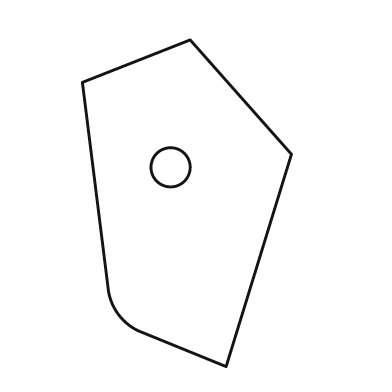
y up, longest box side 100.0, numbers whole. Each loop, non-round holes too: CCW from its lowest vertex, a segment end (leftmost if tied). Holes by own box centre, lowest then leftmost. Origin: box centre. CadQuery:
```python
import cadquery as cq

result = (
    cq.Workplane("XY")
    .moveTo(12.0, -50.0)
    .lineTo(32.0, 15.0)
    .lineTo(1.0, 50.0)
    .lineTo(-32.0, 37.0)
    .lineTo(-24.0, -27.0)
    .threePointArc((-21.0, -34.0), (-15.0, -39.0))
    .close()
    .moveTo(-5.0, 11.0)
    .circle(6.0)
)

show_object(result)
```